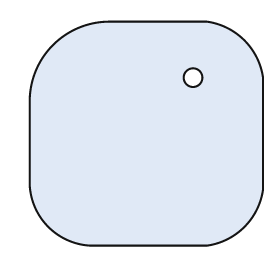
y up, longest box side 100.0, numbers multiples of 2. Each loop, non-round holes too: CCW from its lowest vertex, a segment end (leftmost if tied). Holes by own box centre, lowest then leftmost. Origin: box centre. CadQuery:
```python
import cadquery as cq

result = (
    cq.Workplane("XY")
    .moveTo(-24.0, -48.0)
    .lineTo(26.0, -48.0)
    .threePointArc((42.0, -40.0), (50.0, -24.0))
    .lineTo(50.0, 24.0)
    .threePointArc((42.0, 40.0), (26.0, 48.0))
    .lineTo(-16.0, 48.0)
    .threePointArc((-40.0, 38.0), (-50.0, 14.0))
    .lineTo(-50.0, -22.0)
    .threePointArc((-42.0, -40.0), (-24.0, -48.0))
    .close()
    .moveTo(20.0, 24.0)
    .circle(4.0)
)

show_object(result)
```